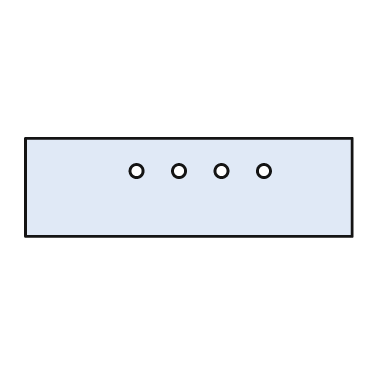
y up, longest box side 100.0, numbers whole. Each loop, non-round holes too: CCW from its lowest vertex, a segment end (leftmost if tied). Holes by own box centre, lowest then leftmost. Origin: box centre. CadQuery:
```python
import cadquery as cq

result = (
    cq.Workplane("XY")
    .moveTo(-50.0, -15.0)
    .lineTo(50.0, -15.0)
    .lineTo(50.0, 15.0)
    .lineTo(-50.0, 15.0)
    .close()
    .moveTo(-16.0, 5.0)
    .circle(2.0)
    .moveTo(-3.0, 5.0)
    .circle(2.0)
    .moveTo(10.0, 5.0)
    .circle(2.0)
    .moveTo(23.0, 5.0)
    .circle(2.0)
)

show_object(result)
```